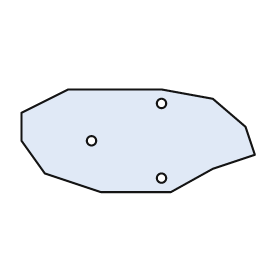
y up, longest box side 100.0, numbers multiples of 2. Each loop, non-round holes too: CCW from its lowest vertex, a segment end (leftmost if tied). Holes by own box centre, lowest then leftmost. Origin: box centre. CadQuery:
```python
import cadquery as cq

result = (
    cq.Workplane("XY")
    .moveTo(-16.0, -22.0)
    .lineTo(14.0, -22.0)
    .lineTo(32.0, -12.0)
    .lineTo(50.0, -6.0)
    .lineTo(46.0, 6.0)
    .lineTo(32.0, 18.0)
    .lineTo(10.0, 22.0)
    .lineTo(-30.0, 22.0)
    .lineTo(-50.0, 12.0)
    .lineTo(-50.0, 0.0)
    .lineTo(-40.0, -14.0)
    .close()
    .moveTo(10.0, -16.0)
    .circle(2.0)
    .moveTo(-20.0, 0.0)
    .circle(2.0)
    .moveTo(10.0, 16.0)
    .circle(2.0)
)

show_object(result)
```